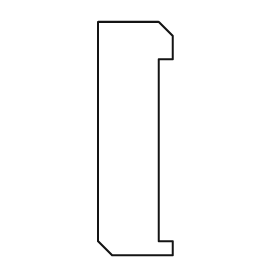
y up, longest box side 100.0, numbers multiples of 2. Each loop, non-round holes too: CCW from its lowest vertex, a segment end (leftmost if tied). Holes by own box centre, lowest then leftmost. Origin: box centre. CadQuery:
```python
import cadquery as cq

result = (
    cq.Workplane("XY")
    .moveTo(-10.0, -50.0)
    .lineTo(16.0, -50.0)
    .lineTo(16.0, -44.0)
    .lineTo(10.0, -44.0)
    .lineTo(10.0, 34.0)
    .lineTo(16.0, 34.0)
    .lineTo(16.0, 44.0)
    .lineTo(10.0, 50.0)
    .lineTo(-16.0, 50.0)
    .lineTo(-16.0, -44.0)
    .close()
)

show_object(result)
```